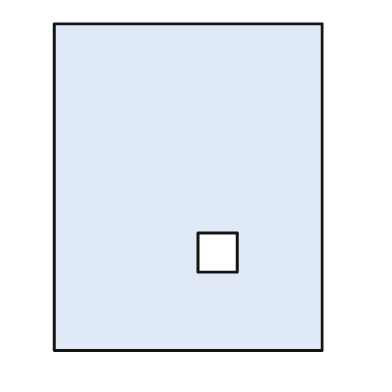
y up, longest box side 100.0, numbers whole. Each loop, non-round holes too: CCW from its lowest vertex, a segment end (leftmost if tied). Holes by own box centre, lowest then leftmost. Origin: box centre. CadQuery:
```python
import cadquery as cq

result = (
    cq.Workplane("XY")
    .moveTo(-41.0, -50.0)
    .lineTo(41.0, -50.0)
    .lineTo(41.0, 50.0)
    .lineTo(-41.0, 50.0)
    .close()
    .moveTo(3.0, -26.0)
    .lineTo(15.0, -26.0)
    .lineTo(15.0, -14.0)
    .lineTo(3.0, -14.0)
    .close()
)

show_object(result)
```